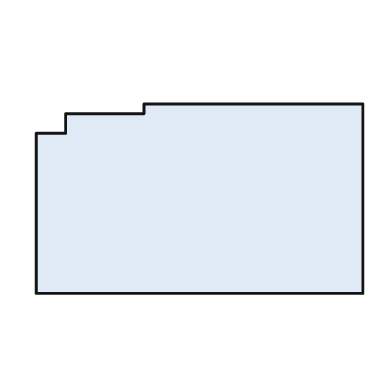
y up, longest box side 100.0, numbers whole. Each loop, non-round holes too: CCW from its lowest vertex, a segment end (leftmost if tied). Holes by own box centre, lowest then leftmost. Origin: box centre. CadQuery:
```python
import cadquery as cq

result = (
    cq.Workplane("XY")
    .moveTo(-50.0, -29.0)
    .lineTo(50.0, -29.0)
    .lineTo(50.0, 29.0)
    .lineTo(-17.0, 29.0)
    .lineTo(-17.0, 26.0)
    .lineTo(-41.0, 26.0)
    .lineTo(-41.0, 20.0)
    .lineTo(-50.0, 20.0)
    .close()
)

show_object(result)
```